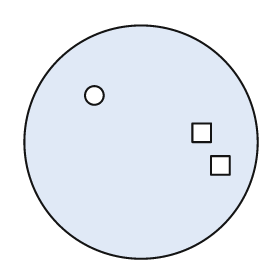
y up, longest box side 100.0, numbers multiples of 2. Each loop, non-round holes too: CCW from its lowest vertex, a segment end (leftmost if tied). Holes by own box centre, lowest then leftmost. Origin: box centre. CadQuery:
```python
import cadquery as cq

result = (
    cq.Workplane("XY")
    .moveTo(0.0, 0.0)
    .circle(50.0)
    .moveTo(30.0, -14.0)
    .lineTo(38.0, -14.0)
    .lineTo(38.0, -6.0)
    .lineTo(30.0, -6.0)
    .close()
    .moveTo(22.0, 0.0)
    .lineTo(30.0, 0.0)
    .lineTo(30.0, 8.0)
    .lineTo(22.0, 8.0)
    .close()
    .moveTo(-20.0, 20.0)
    .circle(4.0)
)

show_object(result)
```